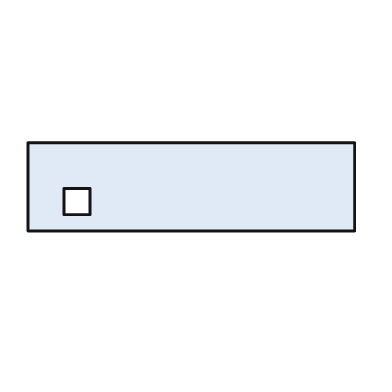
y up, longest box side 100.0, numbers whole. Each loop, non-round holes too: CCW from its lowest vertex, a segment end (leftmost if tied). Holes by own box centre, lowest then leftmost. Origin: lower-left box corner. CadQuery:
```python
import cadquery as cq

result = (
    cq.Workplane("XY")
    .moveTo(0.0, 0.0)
    .lineTo(100.0, 0.0)
    .lineTo(100.0, 27.0)
    .lineTo(0.0, 27.0)
    .close()
    .moveTo(11.0, 5.0)
    .lineTo(19.0, 5.0)
    .lineTo(19.0, 13.0)
    .lineTo(11.0, 13.0)
    .close()
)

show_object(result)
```